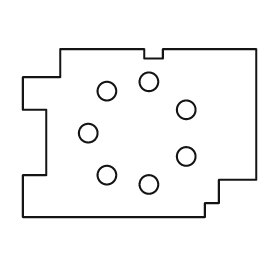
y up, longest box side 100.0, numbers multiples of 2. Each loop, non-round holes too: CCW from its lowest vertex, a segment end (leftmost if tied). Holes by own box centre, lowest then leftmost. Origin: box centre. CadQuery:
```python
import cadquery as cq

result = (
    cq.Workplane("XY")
    .moveTo(-50.0, -36.0)
    .lineTo(28.0, -36.0)
    .lineTo(28.0, -30.0)
    .lineTo(34.0, -30.0)
    .lineTo(34.0, -20.0)
    .lineTo(50.0, -20.0)
    .lineTo(50.0, 36.0)
    .lineTo(10.0, 36.0)
    .lineTo(10.0, 32.0)
    .lineTo(2.0, 32.0)
    .lineTo(2.0, 36.0)
    .lineTo(-34.0, 36.0)
    .lineTo(-34.0, 24.0)
    .lineTo(-50.0, 24.0)
    .lineTo(-50.0, 10.0)
    .lineTo(-40.0, 10.0)
    .lineTo(-40.0, -18.0)
    .lineTo(-50.0, -18.0)
    .close()
    .moveTo(4.0, -22.0)
    .circle(4.0)
    .moveTo(-14.0, -18.0)
    .circle(4.0)
    .moveTo(20.0, -10.0)
    .circle(4.0)
    .moveTo(-22.0, 0.0)
    .circle(4.0)
    .moveTo(20.0, 10.0)
    .circle(4.0)
    .moveTo(-14.0, 18.0)
    .circle(4.0)
    .moveTo(4.0, 22.0)
    .circle(4.0)
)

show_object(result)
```